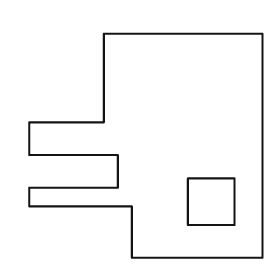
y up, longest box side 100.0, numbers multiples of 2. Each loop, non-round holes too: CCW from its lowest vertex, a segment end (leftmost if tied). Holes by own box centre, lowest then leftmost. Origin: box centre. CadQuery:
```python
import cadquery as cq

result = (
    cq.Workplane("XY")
    .moveTo(-6.0, -48.0)
    .lineTo(50.0, -48.0)
    .lineTo(50.0, 48.0)
    .lineTo(-18.0, 48.0)
    .lineTo(-18.0, 10.0)
    .lineTo(-50.0, 10.0)
    .lineTo(-50.0, -4.0)
    .lineTo(-12.0, -4.0)
    .lineTo(-12.0, -18.0)
    .lineTo(-50.0, -18.0)
    .lineTo(-50.0, -26.0)
    .lineTo(-6.0, -26.0)
    .close()
    .moveTo(18.0, -34.0)
    .lineTo(38.0, -34.0)
    .lineTo(38.0, -14.0)
    .lineTo(18.0, -14.0)
    .close()
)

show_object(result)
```